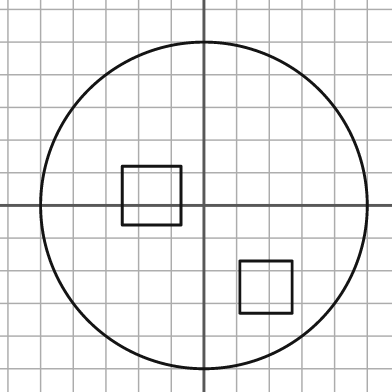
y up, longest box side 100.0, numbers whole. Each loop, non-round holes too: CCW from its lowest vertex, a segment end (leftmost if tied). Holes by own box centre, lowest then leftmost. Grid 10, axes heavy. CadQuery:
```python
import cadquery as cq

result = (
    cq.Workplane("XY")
    .moveTo(0.0, 0.0)
    .circle(50.0)
    .moveTo(11.0, -33.0)
    .lineTo(27.0, -33.0)
    .lineTo(27.0, -17.0)
    .lineTo(11.0, -17.0)
    .close()
    .moveTo(-25.0, -6.0)
    .lineTo(-7.0, -6.0)
    .lineTo(-7.0, 12.0)
    .lineTo(-25.0, 12.0)
    .close()
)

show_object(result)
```